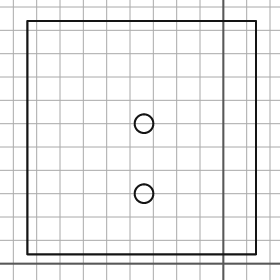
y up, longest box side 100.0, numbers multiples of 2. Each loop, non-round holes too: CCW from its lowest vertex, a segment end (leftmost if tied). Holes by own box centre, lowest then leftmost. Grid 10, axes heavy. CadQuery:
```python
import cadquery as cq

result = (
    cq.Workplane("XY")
    .moveTo(-84.0, 4.0)
    .lineTo(14.0, 4.0)
    .lineTo(14.0, 104.0)
    .lineTo(-84.0, 104.0)
    .close()
    .moveTo(-34.0, 30.0)
    .circle(4.0)
    .moveTo(-34.0, 60.0)
    .circle(4.0)
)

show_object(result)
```